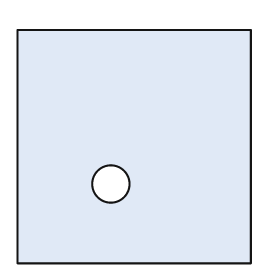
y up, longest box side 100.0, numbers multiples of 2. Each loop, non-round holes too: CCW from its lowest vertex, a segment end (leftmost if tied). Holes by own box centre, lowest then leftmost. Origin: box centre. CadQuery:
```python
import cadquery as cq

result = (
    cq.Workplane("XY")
    .moveTo(-50.0, -50.0)
    .lineTo(50.0, -50.0)
    .lineTo(50.0, 50.0)
    .lineTo(-50.0, 50.0)
    .close()
    .moveTo(-10.0, -16.0)
    .circle(8.0)
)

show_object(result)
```